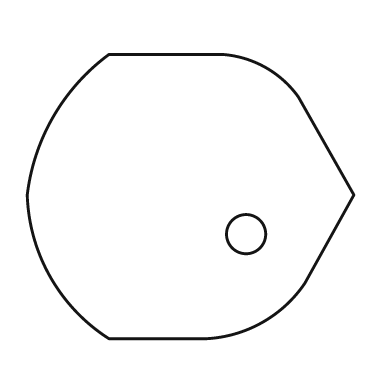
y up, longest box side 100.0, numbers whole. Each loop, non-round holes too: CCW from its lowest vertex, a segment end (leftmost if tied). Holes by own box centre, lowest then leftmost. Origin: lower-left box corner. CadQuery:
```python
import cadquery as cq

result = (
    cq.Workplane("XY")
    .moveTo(25.0, 0.0)
    .lineTo(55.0, 0.0)
    .threePointArc((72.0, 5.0), (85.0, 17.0))
    .lineTo(100.0, 44.0)
    .lineTo(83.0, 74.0)
    .threePointArc((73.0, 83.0), (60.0, 87.0))
    .lineTo(25.0, 87.0)
    .threePointArc((8.0, 68.0), (0.0, 44.0))
    .threePointArc((7.0, 19.0), (25.0, 0.0))
    .close()
    .moveTo(67.0, 32.0)
    .circle(6.0)
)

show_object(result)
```